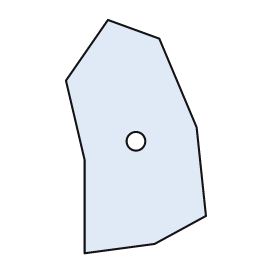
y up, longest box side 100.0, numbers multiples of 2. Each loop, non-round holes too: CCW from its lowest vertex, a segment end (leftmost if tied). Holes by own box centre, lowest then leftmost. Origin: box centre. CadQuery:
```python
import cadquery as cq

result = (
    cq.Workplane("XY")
    .moveTo(-22.0, -50.0)
    .lineTo(8.0, -46.0)
    .lineTo(30.0, -34.0)
    .lineTo(26.0, 4.0)
    .lineTo(10.0, 42.0)
    .lineTo(-12.0, 50.0)
    .lineTo(-30.0, 24.0)
    .lineTo(-22.0, -10.0)
    .close()
    .moveTo(0.0, -2.0)
    .circle(4.0)
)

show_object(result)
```